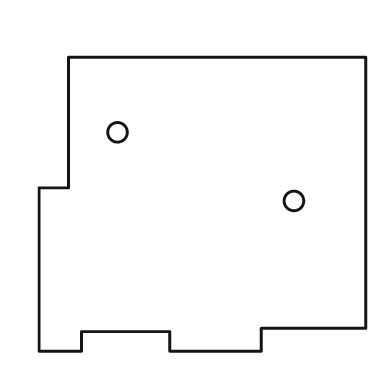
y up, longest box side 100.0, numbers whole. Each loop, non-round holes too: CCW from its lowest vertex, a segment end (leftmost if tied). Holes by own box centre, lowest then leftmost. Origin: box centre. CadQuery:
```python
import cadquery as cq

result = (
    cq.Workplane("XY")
    .moveTo(-50.0, -45.0)
    .lineTo(-37.0, -45.0)
    .lineTo(-37.0, -39.0)
    .lineTo(-10.0, -39.0)
    .lineTo(-10.0, -45.0)
    .lineTo(18.0, -45.0)
    .lineTo(18.0, -38.0)
    .lineTo(50.0, -38.0)
    .lineTo(50.0, 45.0)
    .lineTo(-41.0, 45.0)
    .lineTo(-41.0, 5.0)
    .lineTo(-50.0, 5.0)
    .close()
    .moveTo(28.0, 1.0)
    .circle(3.0)
    .moveTo(-26.0, 22.0)
    .circle(3.0)
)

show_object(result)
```